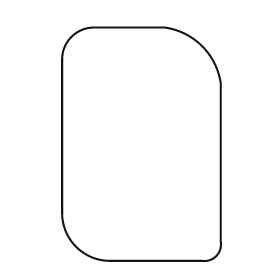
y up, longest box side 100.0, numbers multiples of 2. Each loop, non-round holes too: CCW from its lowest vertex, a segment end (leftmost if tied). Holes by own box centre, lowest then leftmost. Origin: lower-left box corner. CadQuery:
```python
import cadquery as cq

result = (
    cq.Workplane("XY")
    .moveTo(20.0, 0.0)
    .lineTo(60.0, 0.0)
    .threePointArc((66.0, 2.0), (68.0, 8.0))
    .lineTo(68.0, 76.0)
    .threePointArc((60.0, 92.0), (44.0, 100.0))
    .lineTo(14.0, 100.0)
    .threePointArc((4.0, 96.0), (0.0, 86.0))
    .lineTo(0.0, 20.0)
    .threePointArc((6.0, 6.0), (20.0, 0.0))
    .close()
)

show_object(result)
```